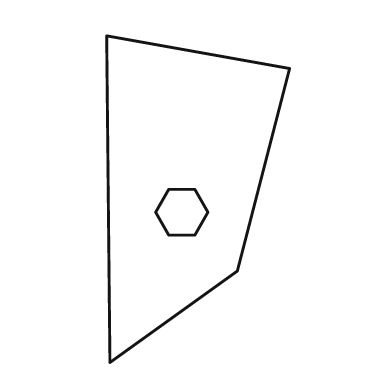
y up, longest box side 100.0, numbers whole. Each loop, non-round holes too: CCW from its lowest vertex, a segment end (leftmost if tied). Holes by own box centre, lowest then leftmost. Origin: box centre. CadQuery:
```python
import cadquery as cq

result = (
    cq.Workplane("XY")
    .moveTo(-27.0, -50.0)
    .lineTo(12.0, -22.0)
    .lineTo(28.0, 40.0)
    .lineTo(-28.0, 50.0)
    .close()
    .moveTo(-9.0, -11.0)
    .lineTo(-1.0, -11.0)
    .lineTo(3.0, -4.0)
    .lineTo(-1.0, 3.0)
    .lineTo(-9.0, 3.0)
    .lineTo(-13.0, -4.0)
    .close()
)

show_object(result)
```